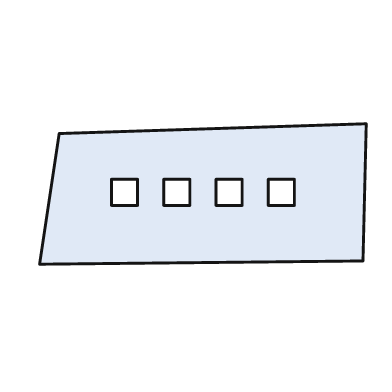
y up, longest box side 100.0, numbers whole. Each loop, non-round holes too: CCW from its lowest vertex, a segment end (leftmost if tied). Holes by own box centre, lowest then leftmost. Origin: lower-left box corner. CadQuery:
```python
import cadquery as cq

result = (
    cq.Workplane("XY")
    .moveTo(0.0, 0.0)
    .lineTo(99.0, 1.0)
    .lineTo(100.0, 43.0)
    .lineTo(6.0, 40.0)
    .close()
    .moveTo(22.0, 18.0)
    .lineTo(30.0, 18.0)
    .lineTo(30.0, 26.0)
    .lineTo(22.0, 26.0)
    .close()
    .moveTo(38.0, 18.0)
    .lineTo(46.0, 18.0)
    .lineTo(46.0, 26.0)
    .lineTo(38.0, 26.0)
    .close()
    .moveTo(54.0, 18.0)
    .lineTo(62.0, 18.0)
    .lineTo(62.0, 26.0)
    .lineTo(54.0, 26.0)
    .close()
    .moveTo(70.0, 18.0)
    .lineTo(78.0, 18.0)
    .lineTo(78.0, 26.0)
    .lineTo(70.0, 26.0)
    .close()
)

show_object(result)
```